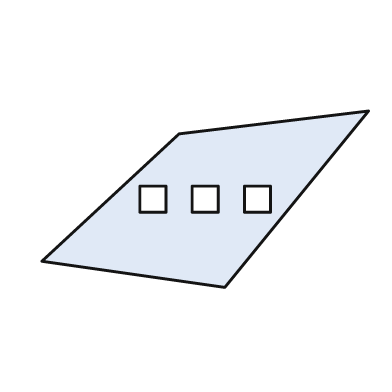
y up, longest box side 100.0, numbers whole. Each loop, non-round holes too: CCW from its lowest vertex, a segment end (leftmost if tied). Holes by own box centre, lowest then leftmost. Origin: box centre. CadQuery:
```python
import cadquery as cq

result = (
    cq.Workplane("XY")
    .moveTo(6.0, -27.0)
    .lineTo(50.0, 27.0)
    .lineTo(-8.0, 20.0)
    .lineTo(-50.0, -19.0)
    .close()
    .moveTo(-20.0, -4.0)
    .lineTo(-12.0, -4.0)
    .lineTo(-12.0, 4.0)
    .lineTo(-20.0, 4.0)
    .close()
    .moveTo(-4.0, -4.0)
    .lineTo(4.0, -4.0)
    .lineTo(4.0, 4.0)
    .lineTo(-4.0, 4.0)
    .close()
    .moveTo(12.0, -4.0)
    .lineTo(20.0, -4.0)
    .lineTo(20.0, 4.0)
    .lineTo(12.0, 4.0)
    .close()
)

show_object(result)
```